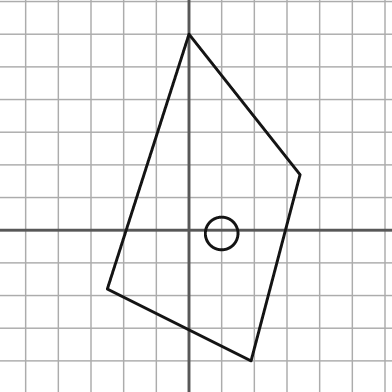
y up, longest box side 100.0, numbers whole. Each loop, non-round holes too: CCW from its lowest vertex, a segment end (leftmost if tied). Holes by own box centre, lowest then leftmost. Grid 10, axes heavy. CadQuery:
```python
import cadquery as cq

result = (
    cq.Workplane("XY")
    .moveTo(19.0, -40.0)
    .lineTo(34.0, 17.0)
    .lineTo(0.0, 60.0)
    .lineTo(-25.0, -18.0)
    .close()
    .moveTo(10.0, -1.0)
    .circle(5.0)
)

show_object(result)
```